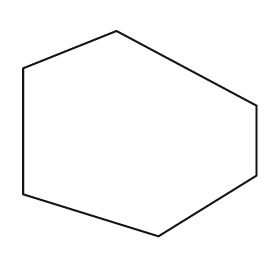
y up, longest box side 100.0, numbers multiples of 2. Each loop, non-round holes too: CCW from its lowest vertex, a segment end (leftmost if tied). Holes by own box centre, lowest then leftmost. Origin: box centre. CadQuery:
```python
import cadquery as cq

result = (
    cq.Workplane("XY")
    .moveTo(8.0, -44.0)
    .lineTo(50.0, -18.0)
    .lineTo(50.0, 12.0)
    .lineTo(-10.0, 44.0)
    .lineTo(-50.0, 28.0)
    .lineTo(-50.0, -26.0)
    .close()
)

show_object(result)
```